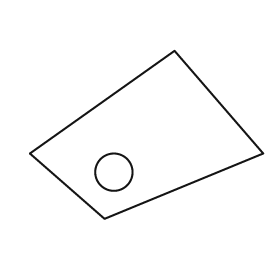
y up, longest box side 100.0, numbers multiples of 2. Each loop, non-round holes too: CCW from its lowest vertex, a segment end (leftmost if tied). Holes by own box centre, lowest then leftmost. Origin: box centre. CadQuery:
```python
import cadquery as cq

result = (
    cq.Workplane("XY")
    .moveTo(-18.0, -36.0)
    .lineTo(50.0, -8.0)
    .lineTo(12.0, 36.0)
    .lineTo(-50.0, -8.0)
    .close()
    .moveTo(-14.0, -16.0)
    .circle(8.0)
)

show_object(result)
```